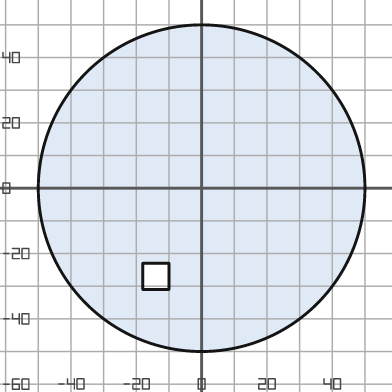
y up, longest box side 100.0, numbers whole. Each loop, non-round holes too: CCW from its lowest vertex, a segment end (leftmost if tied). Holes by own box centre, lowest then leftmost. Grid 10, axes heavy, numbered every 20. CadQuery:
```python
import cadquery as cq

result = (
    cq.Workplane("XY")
    .moveTo(0.0, 0.0)
    .circle(50.0)
    .moveTo(-18.0, -31.0)
    .lineTo(-10.0, -31.0)
    .lineTo(-10.0, -23.0)
    .lineTo(-18.0, -23.0)
    .close()
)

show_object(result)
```